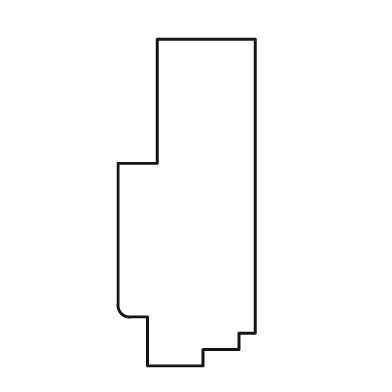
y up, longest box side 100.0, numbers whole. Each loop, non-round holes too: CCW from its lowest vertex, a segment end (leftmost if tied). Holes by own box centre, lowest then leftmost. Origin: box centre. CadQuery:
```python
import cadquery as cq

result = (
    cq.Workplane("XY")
    .moveTo(-12.0, -50.0)
    .lineTo(5.0, -50.0)
    .lineTo(5.0, -45.0)
    .lineTo(16.0, -45.0)
    .lineTo(16.0, -40.0)
    .lineTo(21.0, -40.0)
    .lineTo(21.0, 50.0)
    .lineTo(-9.0, 50.0)
    .lineTo(-9.0, 12.0)
    .lineTo(-21.0, 12.0)
    .lineTo(-21.0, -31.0)
    .threePointArc((-20.0, -34.0), (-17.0, -35.0))
    .lineTo(-12.0, -35.0)
    .close()
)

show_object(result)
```